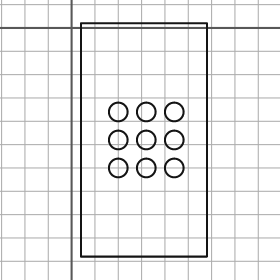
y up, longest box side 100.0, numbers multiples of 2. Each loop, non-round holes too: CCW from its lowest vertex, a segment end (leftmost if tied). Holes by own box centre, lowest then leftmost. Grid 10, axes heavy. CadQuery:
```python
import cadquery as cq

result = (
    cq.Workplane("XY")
    .moveTo(4.0, -98.0)
    .lineTo(58.0, -98.0)
    .lineTo(58.0, 2.0)
    .lineTo(4.0, 2.0)
    .close()
    .moveTo(20.0, -60.0)
    .circle(4.0)
    .moveTo(32.0, -60.0)
    .circle(4.0)
    .moveTo(44.0, -60.0)
    .circle(4.0)
    .moveTo(20.0, -48.0)
    .circle(4.0)
    .moveTo(32.0, -48.0)
    .circle(4.0)
    .moveTo(44.0, -48.0)
    .circle(4.0)
    .moveTo(20.0, -36.0)
    .circle(4.0)
    .moveTo(32.0, -36.0)
    .circle(4.0)
    .moveTo(44.0, -36.0)
    .circle(4.0)
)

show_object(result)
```